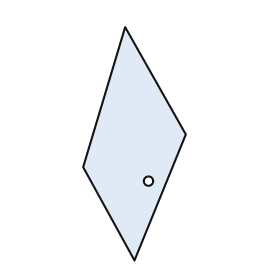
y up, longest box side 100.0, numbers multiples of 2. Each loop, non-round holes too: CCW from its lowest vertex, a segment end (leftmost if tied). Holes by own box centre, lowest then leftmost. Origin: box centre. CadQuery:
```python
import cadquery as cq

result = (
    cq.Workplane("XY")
    .moveTo(0.0, -50.0)
    .lineTo(22.0, 4.0)
    .lineTo(-4.0, 50.0)
    .lineTo(-22.0, -10.0)
    .close()
    .moveTo(6.0, -16.0)
    .circle(2.0)
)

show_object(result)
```